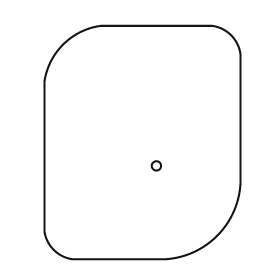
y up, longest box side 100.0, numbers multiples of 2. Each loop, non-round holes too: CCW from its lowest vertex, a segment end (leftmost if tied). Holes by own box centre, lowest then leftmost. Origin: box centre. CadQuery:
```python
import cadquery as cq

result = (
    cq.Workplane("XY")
    .moveTo(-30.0, -50.0)
    .lineTo(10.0, -50.0)
    .threePointArc((32.0, -40.0), (42.0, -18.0))
    .lineTo(42.0, 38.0)
    .threePointArc((38.0, 46.0), (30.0, 50.0))
    .lineTo(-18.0, 50.0)
    .threePointArc((-34.0, 42.0), (-42.0, 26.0))
    .lineTo(-42.0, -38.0)
    .threePointArc((-38.0, -46.0), (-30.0, -50.0))
    .close()
    .moveTo(6.0, -10.0)
    .circle(2.0)
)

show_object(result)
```